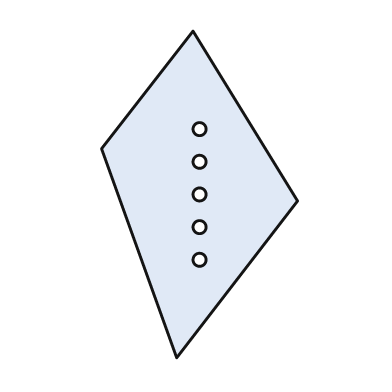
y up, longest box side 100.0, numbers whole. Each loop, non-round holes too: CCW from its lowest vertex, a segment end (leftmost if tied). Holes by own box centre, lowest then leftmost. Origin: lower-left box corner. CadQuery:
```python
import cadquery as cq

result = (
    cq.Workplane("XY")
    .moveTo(23.0, 0.0)
    .lineTo(60.0, 48.0)
    .lineTo(28.0, 100.0)
    .lineTo(0.0, 64.0)
    .close()
    .moveTo(30.0, 30.0)
    .circle(2.0)
    .moveTo(30.0, 40.0)
    .circle(2.0)
    .moveTo(30.0, 50.0)
    .circle(2.0)
    .moveTo(30.0, 60.0)
    .circle(2.0)
    .moveTo(30.0, 70.0)
    .circle(2.0)
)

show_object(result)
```